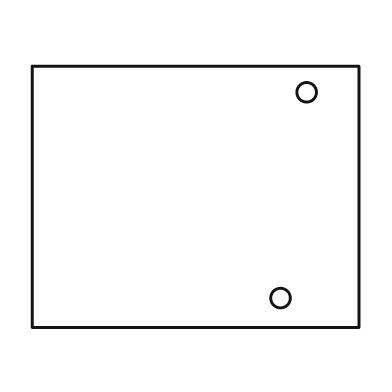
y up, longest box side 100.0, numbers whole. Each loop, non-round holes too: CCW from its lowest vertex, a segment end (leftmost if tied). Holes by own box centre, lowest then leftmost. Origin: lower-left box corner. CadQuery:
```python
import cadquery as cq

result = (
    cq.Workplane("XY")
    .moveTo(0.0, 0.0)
    .lineTo(100.0, 0.0)
    .lineTo(100.0, 80.0)
    .lineTo(0.0, 80.0)
    .close()
    .moveTo(76.0, 9.0)
    .circle(3.0)
    .moveTo(84.0, 72.0)
    .circle(3.0)
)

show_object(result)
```